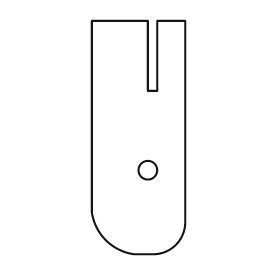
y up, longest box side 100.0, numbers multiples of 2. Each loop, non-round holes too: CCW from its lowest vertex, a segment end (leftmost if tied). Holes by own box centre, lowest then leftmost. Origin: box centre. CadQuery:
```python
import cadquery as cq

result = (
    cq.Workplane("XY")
    .moveTo(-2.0, -50.0)
    .lineTo(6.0, -50.0)
    .threePointArc((16.0, -46.0), (20.0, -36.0))
    .lineTo(20.0, 50.0)
    .lineTo(8.0, 50.0)
    .lineTo(8.0, 20.0)
    .lineTo(4.0, 20.0)
    .lineTo(4.0, 50.0)
    .lineTo(-20.0, 50.0)
    .lineTo(-20.0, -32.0)
    .threePointArc((-14.0, -44.0), (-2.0, -50.0))
    .close()
    .moveTo(4.0, -14.0)
    .circle(4.0)
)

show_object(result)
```